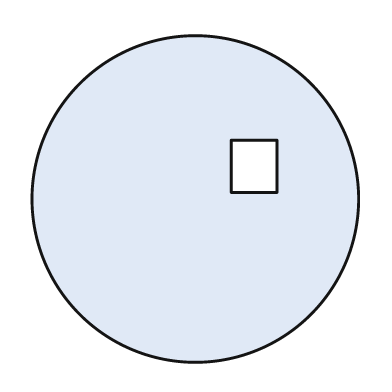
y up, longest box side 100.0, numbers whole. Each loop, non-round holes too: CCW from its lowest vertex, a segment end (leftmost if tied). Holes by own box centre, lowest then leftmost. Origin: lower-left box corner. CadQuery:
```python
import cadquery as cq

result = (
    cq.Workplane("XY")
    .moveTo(50.0, 50.0)
    .circle(50.0)
    .moveTo(61.0, 52.0)
    .lineTo(75.0, 52.0)
    .lineTo(75.0, 68.0)
    .lineTo(61.0, 68.0)
    .close()
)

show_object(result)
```